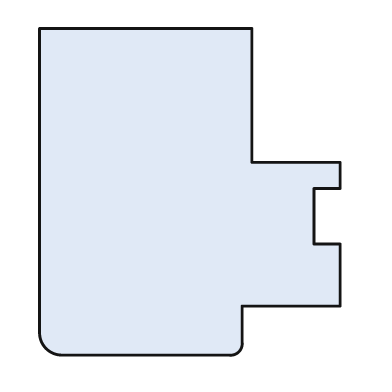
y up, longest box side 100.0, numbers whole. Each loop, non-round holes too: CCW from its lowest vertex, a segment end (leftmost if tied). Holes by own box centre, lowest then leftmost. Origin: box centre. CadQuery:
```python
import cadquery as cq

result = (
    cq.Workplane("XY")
    .moveTo(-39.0, -50.0)
    .lineTo(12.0, -50.0)
    .threePointArc((15.0, -49.0), (16.0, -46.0))
    .lineTo(16.0, -35.0)
    .lineTo(46.0, -35.0)
    .lineTo(46.0, -16.0)
    .lineTo(38.0, -16.0)
    .lineTo(38.0, 1.0)
    .lineTo(46.0, 1.0)
    .lineTo(46.0, 9.0)
    .lineTo(19.0, 9.0)
    .lineTo(19.0, 50.0)
    .lineTo(-46.0, 50.0)
    .lineTo(-46.0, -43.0)
    .threePointArc((-44.0, -48.0), (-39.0, -50.0))
    .close()
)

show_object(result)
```